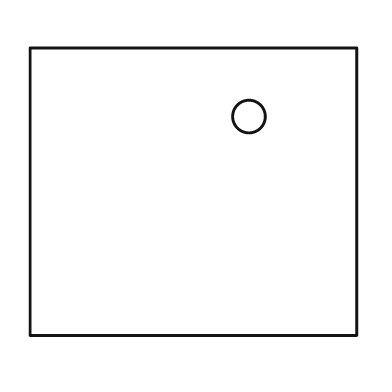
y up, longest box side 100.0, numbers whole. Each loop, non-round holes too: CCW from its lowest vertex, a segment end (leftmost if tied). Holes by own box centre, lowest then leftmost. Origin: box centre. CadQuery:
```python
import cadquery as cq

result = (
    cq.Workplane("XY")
    .moveTo(-50.0, -44.0)
    .lineTo(50.0, -44.0)
    .lineTo(50.0, 44.0)
    .lineTo(-50.0, 44.0)
    .close()
    .moveTo(17.0, 23.0)
    .circle(5.0)
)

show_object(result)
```